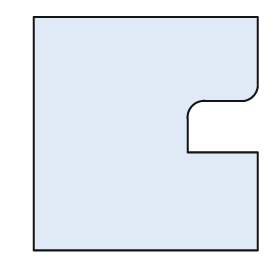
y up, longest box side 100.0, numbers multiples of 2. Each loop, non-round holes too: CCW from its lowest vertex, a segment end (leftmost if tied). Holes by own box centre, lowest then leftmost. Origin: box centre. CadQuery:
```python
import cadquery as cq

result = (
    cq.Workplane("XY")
    .moveTo(-48.0, -50.0)
    .lineTo(48.0, -50.0)
    .lineTo(48.0, -8.0)
    .lineTo(18.0, -8.0)
    .lineTo(18.0, 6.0)
    .threePointArc((20.0, 12.0), (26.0, 14.0))
    .lineTo(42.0, 14.0)
    .threePointArc((46.0, 16.0), (48.0, 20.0))
    .lineTo(48.0, 50.0)
    .lineTo(-48.0, 50.0)
    .close()
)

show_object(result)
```